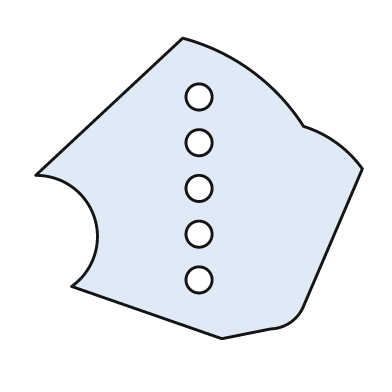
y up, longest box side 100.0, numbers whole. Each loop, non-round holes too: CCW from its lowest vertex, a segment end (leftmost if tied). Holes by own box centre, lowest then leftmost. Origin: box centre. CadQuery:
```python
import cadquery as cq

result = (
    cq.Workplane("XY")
    .moveTo(7.0, -46.0)
    .lineTo(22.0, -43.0)
    .threePointArc((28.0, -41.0), (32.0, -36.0))
    .lineTo(50.0, 6.0)
    .threePointArc((42.0, 14.0), (32.0, 19.0))
    .threePointArc((16.0, 36.0), (-5.0, 46.0))
    .lineTo(-50.0, 4.0)
    .threePointArc((-32.0, -9.0), (-39.0, -30.0))
    .close()
    .moveTo(0.0, -28.0)
    .circle(4.0)
    .moveTo(0.0, -14.0)
    .circle(4.0)
    .moveTo(0.0, 0.0)
    .circle(4.0)
    .moveTo(0.0, 14.0)
    .circle(4.0)
    .moveTo(0.0, 28.0)
    .circle(4.0)
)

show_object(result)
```